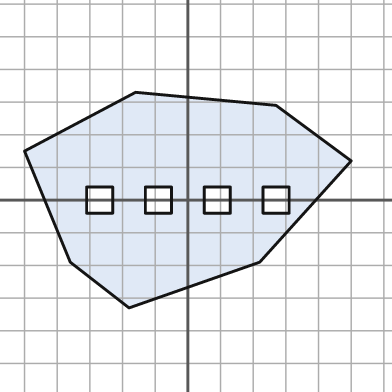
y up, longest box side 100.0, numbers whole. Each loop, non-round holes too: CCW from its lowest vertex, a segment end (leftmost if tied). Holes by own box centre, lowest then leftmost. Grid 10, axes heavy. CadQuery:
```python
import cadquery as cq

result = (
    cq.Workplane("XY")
    .moveTo(-18.0, -33.0)
    .lineTo(22.0, -19.0)
    .lineTo(50.0, 12.0)
    .lineTo(27.0, 29.0)
    .lineTo(-16.0, 33.0)
    .lineTo(-50.0, 15.0)
    .lineTo(-36.0, -19.0)
    .close()
    .moveTo(-31.0, -4.0)
    .lineTo(-23.0, -4.0)
    .lineTo(-23.0, 4.0)
    .lineTo(-31.0, 4.0)
    .close()
    .moveTo(-13.0, -4.0)
    .lineTo(-5.0, -4.0)
    .lineTo(-5.0, 4.0)
    .lineTo(-13.0, 4.0)
    .close()
    .moveTo(5.0, -4.0)
    .lineTo(13.0, -4.0)
    .lineTo(13.0, 4.0)
    .lineTo(5.0, 4.0)
    .close()
    .moveTo(23.0, -4.0)
    .lineTo(31.0, -4.0)
    .lineTo(31.0, 4.0)
    .lineTo(23.0, 4.0)
    .close()
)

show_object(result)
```